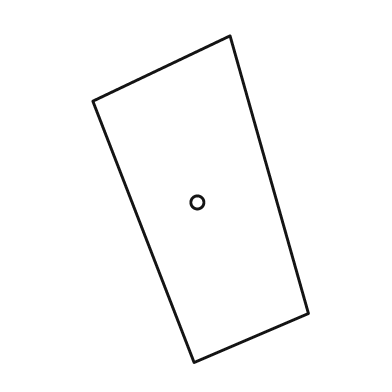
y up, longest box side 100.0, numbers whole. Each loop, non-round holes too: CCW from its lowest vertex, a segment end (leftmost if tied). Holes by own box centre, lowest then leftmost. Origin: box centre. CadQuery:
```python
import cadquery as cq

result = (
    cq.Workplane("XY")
    .moveTo(-2.0, -50.0)
    .lineTo(33.0, -35.0)
    .lineTo(9.0, 50.0)
    .lineTo(-33.0, 30.0)
    .close()
    .moveTo(-1.0, -1.0)
    .circle(2.0)
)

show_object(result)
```